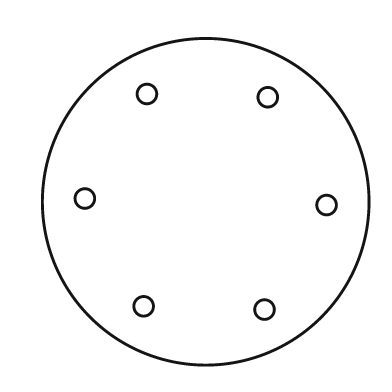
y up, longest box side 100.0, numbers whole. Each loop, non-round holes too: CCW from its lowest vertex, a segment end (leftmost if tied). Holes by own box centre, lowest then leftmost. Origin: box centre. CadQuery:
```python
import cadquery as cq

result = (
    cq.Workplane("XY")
    .moveTo(0.0, 0.0)
    .circle(50.0)
    .moveTo(18.0, -33.0)
    .circle(3.0)
    .moveTo(-19.0, -32.0)
    .circle(3.0)
    .moveTo(37.0, -1.0)
    .circle(3.0)
    .moveTo(-37.0, 1.0)
    .circle(3.0)
    .moveTo(19.0, 32.0)
    .circle(3.0)
    .moveTo(-18.0, 33.0)
    .circle(3.0)
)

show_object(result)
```